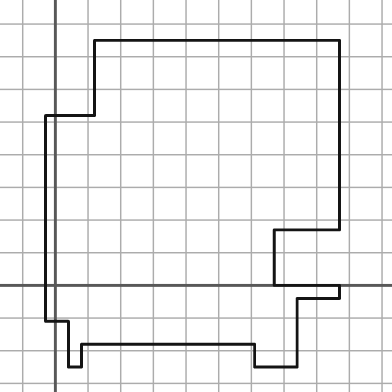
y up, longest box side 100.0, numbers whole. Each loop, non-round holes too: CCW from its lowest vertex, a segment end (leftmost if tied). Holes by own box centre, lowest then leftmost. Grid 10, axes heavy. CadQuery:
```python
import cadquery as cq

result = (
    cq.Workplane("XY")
    .moveTo(4.0, -25.0)
    .lineTo(8.0, -25.0)
    .lineTo(8.0, -18.0)
    .lineTo(61.0, -18.0)
    .lineTo(61.0, -25.0)
    .lineTo(74.0, -25.0)
    .lineTo(74.0, -4.0)
    .lineTo(87.0, -4.0)
    .lineTo(87.0, 0.0)
    .lineTo(67.0, 0.0)
    .lineTo(67.0, 17.0)
    .lineTo(87.0, 17.0)
    .lineTo(87.0, 75.0)
    .lineTo(12.0, 75.0)
    .lineTo(12.0, 52.0)
    .lineTo(-3.0, 52.0)
    .lineTo(-3.0, -11.0)
    .lineTo(4.0, -11.0)
    .close()
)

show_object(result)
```